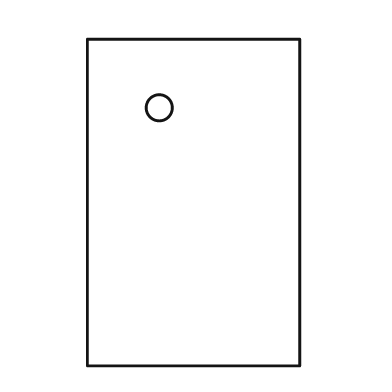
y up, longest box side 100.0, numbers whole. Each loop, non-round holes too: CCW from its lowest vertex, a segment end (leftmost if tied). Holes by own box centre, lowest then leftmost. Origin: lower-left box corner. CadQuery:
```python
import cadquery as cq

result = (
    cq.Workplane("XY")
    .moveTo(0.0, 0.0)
    .lineTo(65.0, 0.0)
    .lineTo(65.0, 100.0)
    .lineTo(0.0, 100.0)
    .close()
    .moveTo(22.0, 79.0)
    .circle(4.0)
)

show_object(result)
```